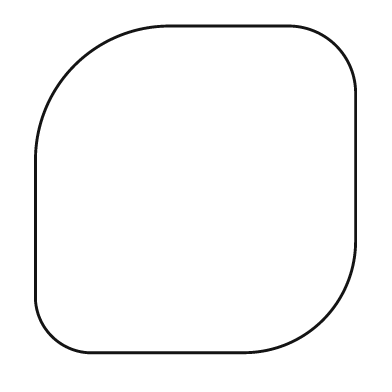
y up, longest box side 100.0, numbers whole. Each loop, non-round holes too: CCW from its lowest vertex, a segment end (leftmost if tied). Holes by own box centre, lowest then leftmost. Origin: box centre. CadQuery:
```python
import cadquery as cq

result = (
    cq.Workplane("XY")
    .moveTo(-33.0, -50.0)
    .lineTo(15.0, -50.0)
    .threePointArc((39.0, -40.0), (49.0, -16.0))
    .lineTo(49.0, 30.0)
    .threePointArc((43.0, 44.0), (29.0, 50.0))
    .lineTo(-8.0, 50.0)
    .threePointArc((-37.0, 38.0), (-49.0, 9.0))
    .lineTo(-49.0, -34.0)
    .threePointArc((-44.0, -45.0), (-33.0, -50.0))
    .close()
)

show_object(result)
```